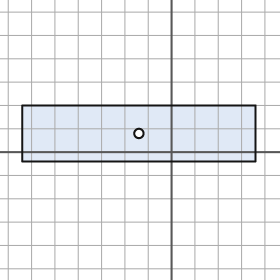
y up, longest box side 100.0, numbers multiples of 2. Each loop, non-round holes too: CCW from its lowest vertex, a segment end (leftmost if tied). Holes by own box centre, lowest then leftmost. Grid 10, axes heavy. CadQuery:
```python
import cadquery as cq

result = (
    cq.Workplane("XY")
    .moveTo(-64.0, -4.0)
    .lineTo(36.0, -4.0)
    .lineTo(36.0, 20.0)
    .lineTo(-64.0, 20.0)
    .close()
    .moveTo(-14.0, 8.0)
    .circle(2.0)
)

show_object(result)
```